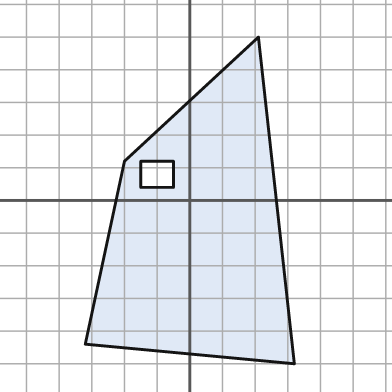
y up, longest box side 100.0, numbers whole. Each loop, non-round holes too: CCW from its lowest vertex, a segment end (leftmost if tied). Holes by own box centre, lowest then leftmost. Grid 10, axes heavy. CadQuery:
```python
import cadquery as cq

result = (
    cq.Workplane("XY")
    .moveTo(32.0, -50.0)
    .lineTo(21.0, 50.0)
    .lineTo(-20.0, 12.0)
    .lineTo(-32.0, -44.0)
    .close()
    .moveTo(-15.0, 4.0)
    .lineTo(-5.0, 4.0)
    .lineTo(-5.0, 12.0)
    .lineTo(-15.0, 12.0)
    .close()
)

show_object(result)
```